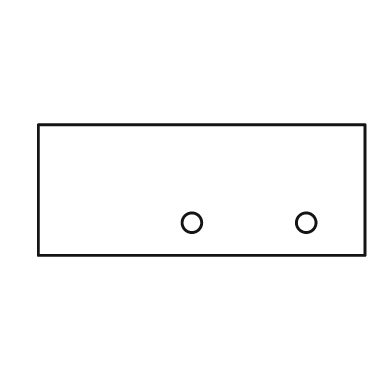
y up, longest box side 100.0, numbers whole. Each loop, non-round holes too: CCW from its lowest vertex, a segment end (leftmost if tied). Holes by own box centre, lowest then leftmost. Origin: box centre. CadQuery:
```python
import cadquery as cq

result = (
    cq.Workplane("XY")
    .moveTo(-50.0, -20.0)
    .lineTo(50.0, -20.0)
    .lineTo(50.0, 20.0)
    .lineTo(-50.0, 20.0)
    .close()
    .moveTo(-3.0, -10.0)
    .circle(3.0)
    .moveTo(32.0, -10.0)
    .circle(3.0)
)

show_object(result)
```